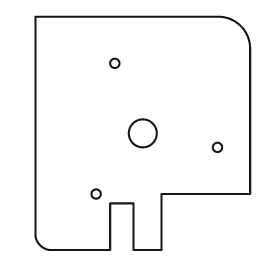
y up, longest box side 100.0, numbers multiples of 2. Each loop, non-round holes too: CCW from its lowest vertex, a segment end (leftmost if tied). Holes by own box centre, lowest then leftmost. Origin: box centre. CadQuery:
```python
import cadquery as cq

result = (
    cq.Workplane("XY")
    .moveTo(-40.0, -50.0)
    .lineTo(-14.0, -50.0)
    .lineTo(-14.0, -30.0)
    .lineTo(-4.0, -30.0)
    .lineTo(-4.0, -50.0)
    .lineTo(8.0, -50.0)
    .lineTo(8.0, -26.0)
    .lineTo(46.0, -26.0)
    .lineTo(46.0, 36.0)
    .threePointArc((42.0, 46.0), (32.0, 50.0))
    .lineTo(-46.0, 50.0)
    .lineTo(-46.0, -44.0)
    .threePointArc((-44.0, -48.0), (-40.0, -50.0))
    .close()
    .moveTo(-20.0, -26.0)
    .circle(2.0)
    .moveTo(32.0, -6.0)
    .circle(2.0)
    .moveTo(0.0, 0.0)
    .circle(6.0)
    .moveTo(-12.0, 30.0)
    .circle(2.0)
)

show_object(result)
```